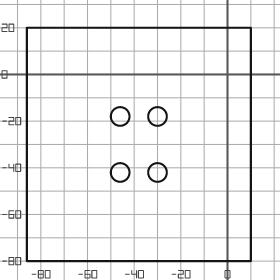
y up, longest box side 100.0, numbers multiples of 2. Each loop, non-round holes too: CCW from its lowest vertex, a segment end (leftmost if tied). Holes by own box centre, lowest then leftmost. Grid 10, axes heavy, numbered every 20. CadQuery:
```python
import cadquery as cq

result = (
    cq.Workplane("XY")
    .moveTo(-86.0, -80.0)
    .lineTo(10.0, -80.0)
    .lineTo(10.0, 20.0)
    .lineTo(-86.0, 20.0)
    .close()
    .moveTo(-46.0, -42.0)
    .circle(4.0)
    .moveTo(-30.0, -42.0)
    .circle(4.0)
    .moveTo(-46.0, -18.0)
    .circle(4.0)
    .moveTo(-30.0, -18.0)
    .circle(4.0)
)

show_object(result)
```